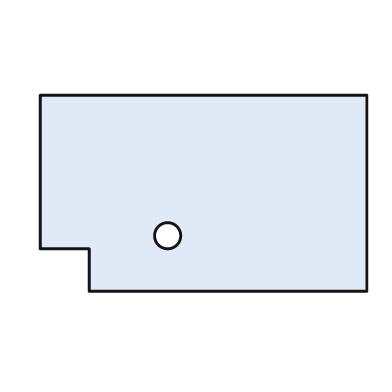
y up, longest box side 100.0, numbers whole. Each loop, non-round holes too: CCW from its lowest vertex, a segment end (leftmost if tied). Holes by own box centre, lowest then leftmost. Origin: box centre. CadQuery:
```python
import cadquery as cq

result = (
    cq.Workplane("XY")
    .moveTo(-35.0, -30.0)
    .lineTo(50.0, -30.0)
    .lineTo(50.0, 30.0)
    .lineTo(-50.0, 30.0)
    .lineTo(-50.0, -17.0)
    .lineTo(-35.0, -17.0)
    .close()
    .moveTo(-11.0, -13.0)
    .circle(4.0)
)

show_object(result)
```